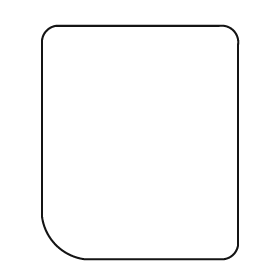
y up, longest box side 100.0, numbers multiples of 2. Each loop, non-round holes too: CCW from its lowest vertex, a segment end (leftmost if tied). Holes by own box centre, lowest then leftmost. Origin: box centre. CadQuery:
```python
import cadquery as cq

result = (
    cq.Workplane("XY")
    .moveTo(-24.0, -50.0)
    .lineTo(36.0, -50.0)
    .threePointArc((40.0, -48.0), (42.0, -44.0))
    .lineTo(42.0, 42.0)
    .threePointArc((40.0, 48.0), (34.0, 50.0))
    .lineTo(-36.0, 50.0)
    .threePointArc((-40.0, 48.0), (-42.0, 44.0))
    .lineTo(-42.0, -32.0)
    .threePointArc((-36.0, -44.0), (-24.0, -50.0))
    .close()
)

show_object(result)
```